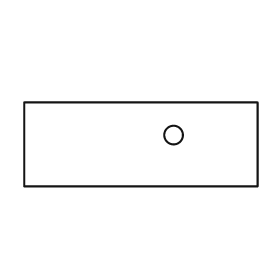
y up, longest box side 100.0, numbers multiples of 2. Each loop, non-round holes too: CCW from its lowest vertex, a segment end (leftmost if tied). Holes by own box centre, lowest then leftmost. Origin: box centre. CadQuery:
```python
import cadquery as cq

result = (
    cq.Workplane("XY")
    .moveTo(-50.0, -18.0)
    .lineTo(50.0, -18.0)
    .lineTo(50.0, 18.0)
    .lineTo(-50.0, 18.0)
    .close()
    .moveTo(14.0, 4.0)
    .circle(4.0)
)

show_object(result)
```